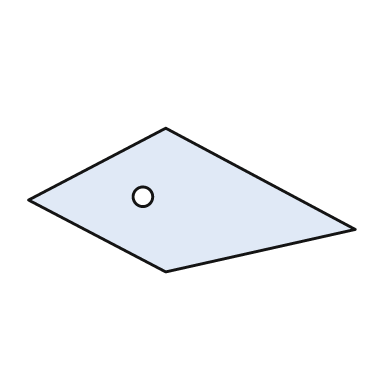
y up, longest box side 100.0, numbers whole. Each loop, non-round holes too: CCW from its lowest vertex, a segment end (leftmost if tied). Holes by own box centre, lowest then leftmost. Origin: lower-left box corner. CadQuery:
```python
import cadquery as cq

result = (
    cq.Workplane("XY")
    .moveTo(42.0, 0.0)
    .lineTo(100.0, 13.0)
    .lineTo(42.0, 44.0)
    .lineTo(0.0, 22.0)
    .close()
    .moveTo(35.0, 23.0)
    .circle(3.0)
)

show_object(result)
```